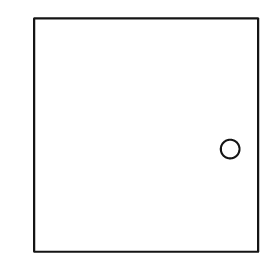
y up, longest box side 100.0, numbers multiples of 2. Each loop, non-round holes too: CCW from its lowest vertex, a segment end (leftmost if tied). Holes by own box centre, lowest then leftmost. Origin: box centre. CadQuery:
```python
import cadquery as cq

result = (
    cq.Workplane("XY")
    .moveTo(-48.0, -50.0)
    .lineTo(48.0, -50.0)
    .lineTo(48.0, 50.0)
    .lineTo(-48.0, 50.0)
    .close()
    .moveTo(36.0, -6.0)
    .circle(4.0)
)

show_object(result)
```